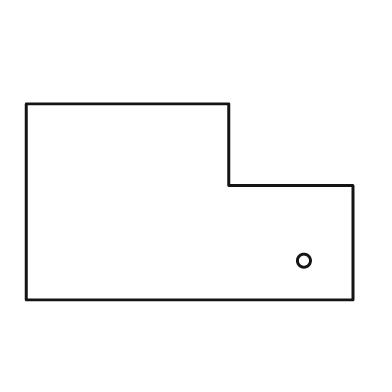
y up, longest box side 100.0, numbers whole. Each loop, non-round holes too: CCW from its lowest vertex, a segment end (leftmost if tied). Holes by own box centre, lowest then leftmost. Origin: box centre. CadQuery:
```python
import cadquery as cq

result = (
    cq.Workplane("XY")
    .moveTo(-50.0, -30.0)
    .lineTo(50.0, -30.0)
    .lineTo(50.0, 5.0)
    .lineTo(12.0, 5.0)
    .lineTo(12.0, 30.0)
    .lineTo(-50.0, 30.0)
    .close()
    .moveTo(35.0, -18.0)
    .circle(2.0)
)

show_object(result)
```